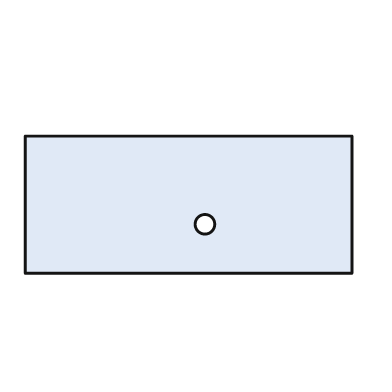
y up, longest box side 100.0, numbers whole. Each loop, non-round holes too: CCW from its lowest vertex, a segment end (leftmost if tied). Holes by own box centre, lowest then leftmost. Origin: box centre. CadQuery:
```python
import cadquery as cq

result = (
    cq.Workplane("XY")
    .moveTo(-50.0, -21.0)
    .lineTo(50.0, -21.0)
    .lineTo(50.0, 21.0)
    .lineTo(-50.0, 21.0)
    .close()
    .moveTo(5.0, -6.0)
    .circle(3.0)
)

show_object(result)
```